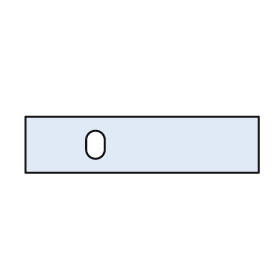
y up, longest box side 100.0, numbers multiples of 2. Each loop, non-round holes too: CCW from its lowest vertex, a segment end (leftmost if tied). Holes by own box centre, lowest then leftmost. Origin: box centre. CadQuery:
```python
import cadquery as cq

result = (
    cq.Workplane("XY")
    .moveTo(-50.0, -12.0)
    .lineTo(50.0, -12.0)
    .lineTo(50.0, 12.0)
    .lineTo(-50.0, 12.0)
    .close()
    .moveTo(-24.0, -2.0)
    .threePointArc((-20.0, -6.0), (-16.0, -2.0))
    .lineTo(-16.0, 2.0)
    .threePointArc((-20.0, 6.0), (-24.0, 2.0))
    .close()
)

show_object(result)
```